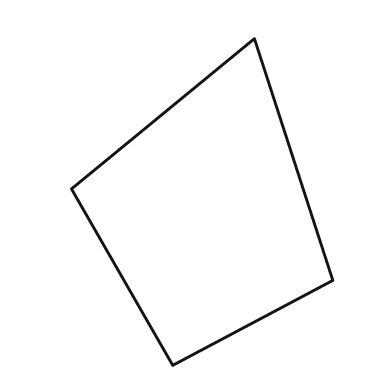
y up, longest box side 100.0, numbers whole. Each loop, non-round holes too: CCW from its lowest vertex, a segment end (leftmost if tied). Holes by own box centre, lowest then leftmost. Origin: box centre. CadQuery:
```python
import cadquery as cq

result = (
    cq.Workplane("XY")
    .moveTo(-9.0, -50.0)
    .lineTo(40.0, -24.0)
    .lineTo(16.0, 50.0)
    .lineTo(-40.0, 4.0)
    .close()
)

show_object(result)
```